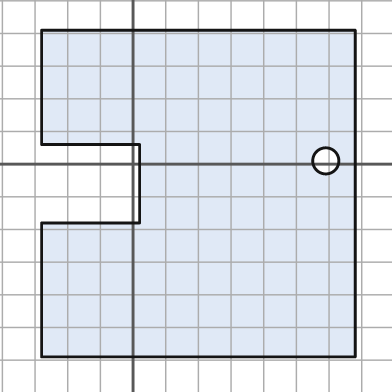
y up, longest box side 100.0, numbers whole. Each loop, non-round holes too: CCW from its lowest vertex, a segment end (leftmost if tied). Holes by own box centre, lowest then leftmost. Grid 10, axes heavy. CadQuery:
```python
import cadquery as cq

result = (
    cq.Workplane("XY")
    .moveTo(-28.0, -59.0)
    .lineTo(68.0, -59.0)
    .lineTo(68.0, 41.0)
    .lineTo(-28.0, 41.0)
    .lineTo(-28.0, 6.0)
    .lineTo(2.0, 6.0)
    .lineTo(2.0, -18.0)
    .lineTo(-28.0, -18.0)
    .close()
    .moveTo(59.0, 1.0)
    .circle(4.0)
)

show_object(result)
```